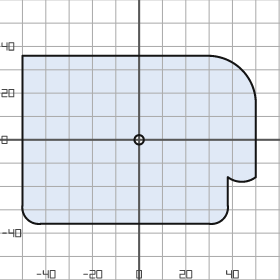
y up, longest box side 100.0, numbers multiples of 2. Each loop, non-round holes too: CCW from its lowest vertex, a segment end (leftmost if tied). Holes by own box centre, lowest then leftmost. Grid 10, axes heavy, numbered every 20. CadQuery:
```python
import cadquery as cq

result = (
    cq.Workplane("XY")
    .moveTo(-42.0, -36.0)
    .lineTo(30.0, -36.0)
    .threePointArc((36.0, -34.0), (38.0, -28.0))
    .lineTo(38.0, -16.0)
    .threePointArc((44.0, -18.0), (50.0, -16.0))
    .lineTo(50.0, 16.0)
    .threePointArc((44.0, 30.0), (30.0, 36.0))
    .lineTo(-50.0, 36.0)
    .lineTo(-50.0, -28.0)
    .threePointArc((-48.0, -34.0), (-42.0, -36.0))
    .close()
    .moveTo(0.0, 0.0)
    .circle(2.0)
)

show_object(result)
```